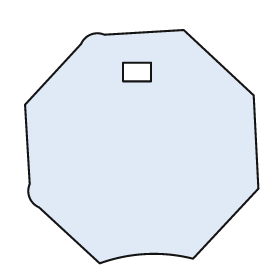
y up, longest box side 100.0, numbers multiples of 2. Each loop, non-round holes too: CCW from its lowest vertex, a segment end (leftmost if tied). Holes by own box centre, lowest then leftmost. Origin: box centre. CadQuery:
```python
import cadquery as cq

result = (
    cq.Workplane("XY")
    .moveTo(-18.0, -50.0)
    .threePointArc((2.0, -46.0), (22.0, -48.0))
    .lineTo(50.0, -18.0)
    .lineTo(48.0, 22.0)
    .lineTo(18.0, 50.0)
    .lineTo(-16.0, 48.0)
    .threePointArc((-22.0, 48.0), (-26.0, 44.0))
    .lineTo(-50.0, 18.0)
    .lineTo(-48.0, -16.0)
    .threePointArc((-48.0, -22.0), (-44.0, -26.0))
    .close()
    .moveTo(-8.0, 28.0)
    .lineTo(4.0, 28.0)
    .lineTo(4.0, 36.0)
    .lineTo(-8.0, 36.0)
    .close()
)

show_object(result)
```